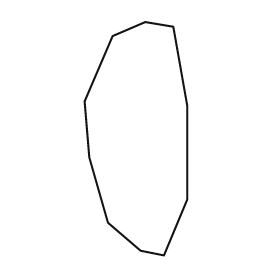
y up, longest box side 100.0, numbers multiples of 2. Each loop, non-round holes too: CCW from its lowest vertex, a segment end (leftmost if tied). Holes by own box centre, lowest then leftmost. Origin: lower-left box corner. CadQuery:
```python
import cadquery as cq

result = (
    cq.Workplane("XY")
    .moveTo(34.0, 0.0)
    .lineTo(44.0, 24.0)
    .lineTo(44.0, 64.0)
    .lineTo(38.0, 98.0)
    .lineTo(26.0, 100.0)
    .lineTo(12.0, 94.0)
    .lineTo(0.0, 66.0)
    .lineTo(2.0, 42.0)
    .lineTo(10.0, 14.0)
    .lineTo(24.0, 2.0)
    .close()
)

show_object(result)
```